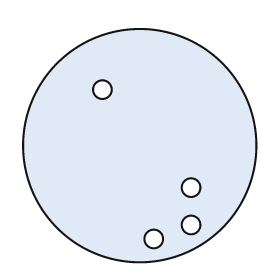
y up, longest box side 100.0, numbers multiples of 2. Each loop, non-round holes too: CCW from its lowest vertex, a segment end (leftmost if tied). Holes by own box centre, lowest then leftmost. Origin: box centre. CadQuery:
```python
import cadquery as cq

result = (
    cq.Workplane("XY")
    .moveTo(0.0, 0.0)
    .circle(50.0)
    .moveTo(6.0, -40.0)
    .circle(4.0)
    .moveTo(22.0, -34.0)
    .circle(4.0)
    .moveTo(22.0, -18.0)
    .circle(4.0)
    .moveTo(-16.0, 24.0)
    .circle(4.0)
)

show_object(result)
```